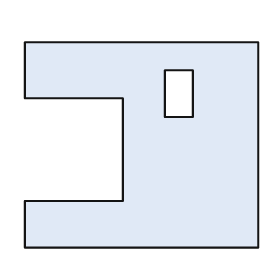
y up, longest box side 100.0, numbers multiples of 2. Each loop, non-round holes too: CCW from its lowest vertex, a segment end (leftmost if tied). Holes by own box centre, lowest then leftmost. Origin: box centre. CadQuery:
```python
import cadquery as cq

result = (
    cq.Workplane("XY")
    .moveTo(-50.0, -44.0)
    .lineTo(50.0, -44.0)
    .lineTo(50.0, 44.0)
    .lineTo(-50.0, 44.0)
    .lineTo(-50.0, 20.0)
    .lineTo(-8.0, 20.0)
    .lineTo(-8.0, -24.0)
    .lineTo(-50.0, -24.0)
    .close()
    .moveTo(10.0, 12.0)
    .lineTo(22.0, 12.0)
    .lineTo(22.0, 32.0)
    .lineTo(10.0, 32.0)
    .close()
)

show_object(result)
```